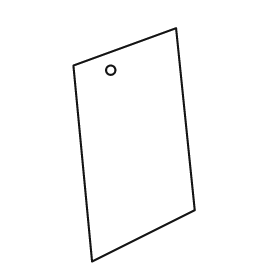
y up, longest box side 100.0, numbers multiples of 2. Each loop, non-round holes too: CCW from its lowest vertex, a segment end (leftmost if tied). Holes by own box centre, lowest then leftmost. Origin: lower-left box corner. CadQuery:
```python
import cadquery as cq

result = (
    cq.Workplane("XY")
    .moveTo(8.0, 0.0)
    .lineTo(52.0, 22.0)
    .lineTo(44.0, 100.0)
    .lineTo(0.0, 84.0)
    .close()
    .moveTo(16.0, 82.0)
    .circle(2.0)
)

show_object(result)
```